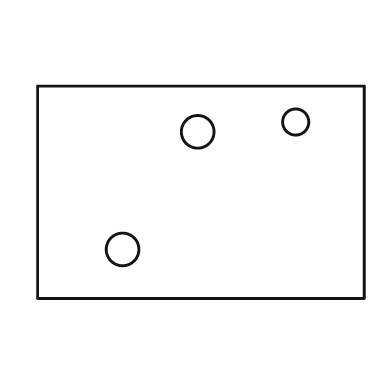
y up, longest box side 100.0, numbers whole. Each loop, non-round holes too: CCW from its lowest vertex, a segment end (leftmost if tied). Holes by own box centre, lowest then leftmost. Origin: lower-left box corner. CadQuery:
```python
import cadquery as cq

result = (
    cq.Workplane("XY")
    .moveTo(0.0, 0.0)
    .lineTo(100.0, 0.0)
    .lineTo(100.0, 65.0)
    .lineTo(0.0, 65.0)
    .close()
    .moveTo(26.0, 15.0)
    .circle(5.0)
    .moveTo(49.0, 51.0)
    .circle(5.0)
    .moveTo(79.0, 54.0)
    .circle(4.0)
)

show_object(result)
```